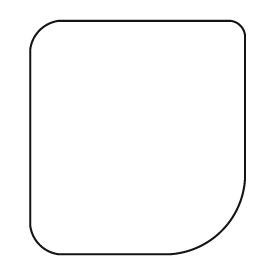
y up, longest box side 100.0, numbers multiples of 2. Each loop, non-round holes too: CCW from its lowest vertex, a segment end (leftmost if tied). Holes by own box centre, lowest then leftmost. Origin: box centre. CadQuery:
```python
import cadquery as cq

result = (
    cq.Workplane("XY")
    .moveTo(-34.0, -50.0)
    .lineTo(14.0, -50.0)
    .threePointArc((36.0, -40.0), (46.0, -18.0))
    .lineTo(46.0, 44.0)
    .threePointArc((44.0, 48.0), (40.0, 50.0))
    .lineTo(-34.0, 50.0)
    .threePointArc((-42.0, 46.0), (-46.0, 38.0))
    .lineTo(-46.0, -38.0)
    .threePointArc((-42.0, -46.0), (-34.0, -50.0))
    .close()
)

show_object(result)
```